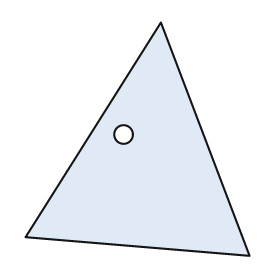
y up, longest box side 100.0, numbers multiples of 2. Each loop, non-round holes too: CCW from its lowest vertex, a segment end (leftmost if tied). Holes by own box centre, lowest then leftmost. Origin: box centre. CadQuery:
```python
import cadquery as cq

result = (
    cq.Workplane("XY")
    .moveTo(48.0, -50.0)
    .lineTo(10.0, 50.0)
    .lineTo(-48.0, -42.0)
    .close()
    .moveTo(-6.0, 2.0)
    .circle(4.0)
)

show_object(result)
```